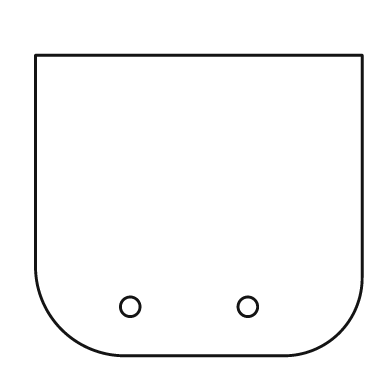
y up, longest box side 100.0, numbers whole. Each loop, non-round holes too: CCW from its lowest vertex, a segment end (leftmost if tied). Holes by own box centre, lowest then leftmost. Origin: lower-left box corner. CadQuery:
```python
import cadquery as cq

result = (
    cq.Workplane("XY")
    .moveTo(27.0, 0.0)
    .lineTo(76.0, 0.0)
    .threePointArc((93.0, 7.0), (100.0, 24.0))
    .lineTo(100.0, 92.0)
    .lineTo(0.0, 92.0)
    .lineTo(0.0, 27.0)
    .threePointArc((8.0, 8.0), (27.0, 0.0))
    .close()
    .moveTo(29.0, 15.0)
    .circle(3.0)
    .moveTo(65.0, 15.0)
    .circle(3.0)
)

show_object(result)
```